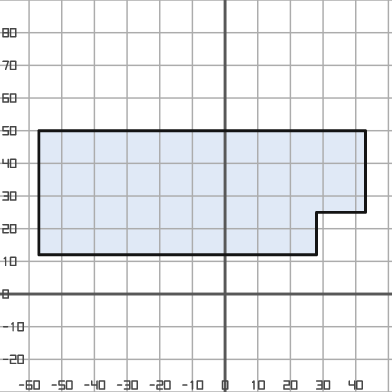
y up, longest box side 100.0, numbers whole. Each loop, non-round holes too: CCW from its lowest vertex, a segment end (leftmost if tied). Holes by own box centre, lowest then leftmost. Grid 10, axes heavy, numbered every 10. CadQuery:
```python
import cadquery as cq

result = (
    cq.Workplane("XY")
    .moveTo(-57.0, 12.0)
    .lineTo(28.0, 12.0)
    .lineTo(28.0, 25.0)
    .lineTo(43.0, 25.0)
    .lineTo(43.0, 50.0)
    .lineTo(-57.0, 50.0)
    .close()
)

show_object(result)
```